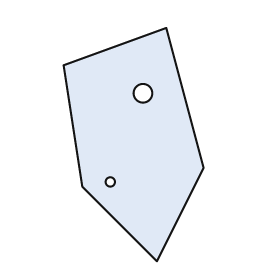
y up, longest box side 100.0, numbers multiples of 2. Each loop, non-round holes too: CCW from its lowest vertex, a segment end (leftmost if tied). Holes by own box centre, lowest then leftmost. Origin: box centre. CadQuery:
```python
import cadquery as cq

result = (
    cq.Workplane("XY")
    .moveTo(10.0, -50.0)
    .lineTo(30.0, -10.0)
    .lineTo(14.0, 50.0)
    .lineTo(-30.0, 34.0)
    .lineTo(-22.0, -18.0)
    .close()
    .moveTo(-10.0, -16.0)
    .circle(2.0)
    .moveTo(4.0, 22.0)
    .circle(4.0)
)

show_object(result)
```